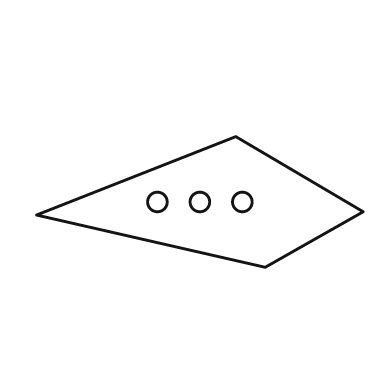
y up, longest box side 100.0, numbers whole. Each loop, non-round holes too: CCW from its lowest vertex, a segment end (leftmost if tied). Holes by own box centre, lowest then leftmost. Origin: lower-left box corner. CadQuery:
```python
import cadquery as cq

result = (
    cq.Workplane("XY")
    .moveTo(70.0, 0.0)
    .lineTo(100.0, 17.0)
    .lineTo(61.0, 40.0)
    .lineTo(0.0, 16.0)
    .close()
    .moveTo(37.0, 20.0)
    .circle(3.0)
    .moveTo(50.0, 20.0)
    .circle(3.0)
    .moveTo(63.0, 20.0)
    .circle(3.0)
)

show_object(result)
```